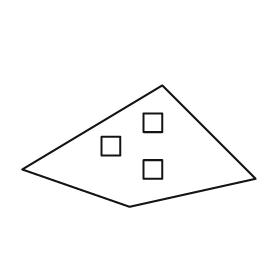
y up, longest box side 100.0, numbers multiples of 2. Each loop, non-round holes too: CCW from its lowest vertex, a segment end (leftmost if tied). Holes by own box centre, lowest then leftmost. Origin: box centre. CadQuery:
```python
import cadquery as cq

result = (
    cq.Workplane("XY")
    .moveTo(-4.0, -26.0)
    .lineTo(50.0, -14.0)
    .lineTo(10.0, 26.0)
    .lineTo(-50.0, -10.0)
    .close()
    .moveTo(2.0, -14.0)
    .lineTo(10.0, -14.0)
    .lineTo(10.0, -6.0)
    .lineTo(2.0, -6.0)
    .close()
    .moveTo(-16.0, -4.0)
    .lineTo(-8.0, -4.0)
    .lineTo(-8.0, 4.0)
    .lineTo(-16.0, 4.0)
    .close()
    .moveTo(2.0, 6.0)
    .lineTo(10.0, 6.0)
    .lineTo(10.0, 14.0)
    .lineTo(2.0, 14.0)
    .close()
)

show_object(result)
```